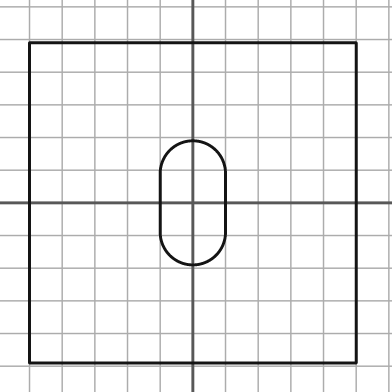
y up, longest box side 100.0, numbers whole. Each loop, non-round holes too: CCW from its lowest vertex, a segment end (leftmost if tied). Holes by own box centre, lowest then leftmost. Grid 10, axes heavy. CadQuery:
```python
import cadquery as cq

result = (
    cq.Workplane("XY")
    .moveTo(-50.0, -49.0)
    .lineTo(50.0, -49.0)
    .lineTo(50.0, 49.0)
    .lineTo(-50.0, 49.0)
    .close()
    .moveTo(-10.0, -9.0)
    .threePointArc((0.0, -19.0), (10.0, -9.0))
    .lineTo(10.0, 9.0)
    .threePointArc((0.0, 19.0), (-10.0, 9.0))
    .close()
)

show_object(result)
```